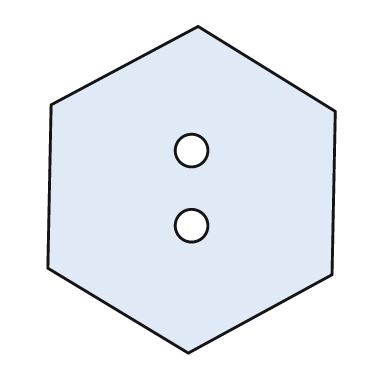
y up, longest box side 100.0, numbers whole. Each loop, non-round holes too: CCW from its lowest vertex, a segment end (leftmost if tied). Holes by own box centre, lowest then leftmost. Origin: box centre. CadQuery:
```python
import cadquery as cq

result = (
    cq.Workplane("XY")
    .moveTo(-1.0, -50.0)
    .lineTo(43.0, -26.0)
    .lineTo(44.0, 24.0)
    .lineTo(2.0, 50.0)
    .lineTo(-43.0, 26.0)
    .lineTo(-44.0, -24.0)
    .close()
    .moveTo(0.0, -11.0)
    .circle(5.0)
    .moveTo(0.0, 12.0)
    .circle(5.0)
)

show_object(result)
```